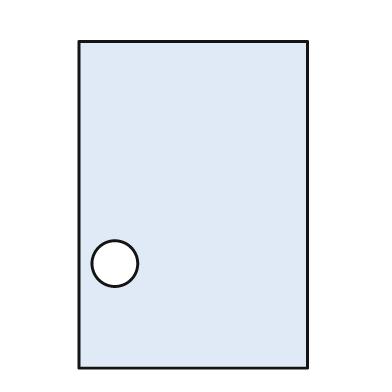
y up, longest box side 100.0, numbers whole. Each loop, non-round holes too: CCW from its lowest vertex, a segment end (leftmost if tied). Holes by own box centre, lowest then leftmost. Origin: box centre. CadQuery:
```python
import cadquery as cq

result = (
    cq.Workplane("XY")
    .moveTo(-35.0, -50.0)
    .lineTo(35.0, -50.0)
    .lineTo(35.0, 50.0)
    .lineTo(-35.0, 50.0)
    .close()
    .moveTo(-24.0, -18.0)
    .circle(7.0)
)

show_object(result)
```